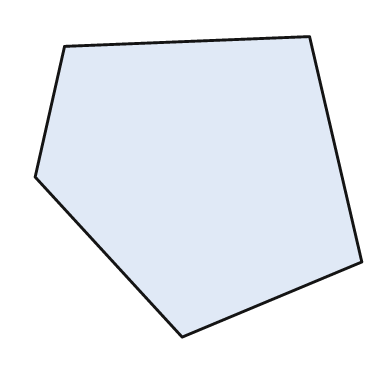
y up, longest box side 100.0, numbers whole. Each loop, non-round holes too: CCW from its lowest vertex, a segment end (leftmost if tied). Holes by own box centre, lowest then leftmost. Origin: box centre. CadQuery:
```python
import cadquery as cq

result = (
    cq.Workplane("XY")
    .moveTo(-5.0, -46.0)
    .lineTo(50.0, -23.0)
    .lineTo(34.0, 46.0)
    .lineTo(-41.0, 43.0)
    .lineTo(-50.0, 3.0)
    .close()
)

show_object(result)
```